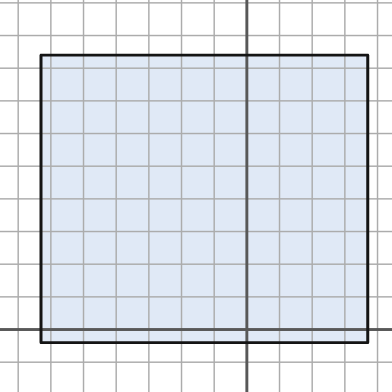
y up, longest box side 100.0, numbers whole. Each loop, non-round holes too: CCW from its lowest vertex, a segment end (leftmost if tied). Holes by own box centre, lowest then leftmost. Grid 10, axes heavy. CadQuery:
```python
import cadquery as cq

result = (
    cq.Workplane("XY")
    .moveTo(-63.0, -4.0)
    .lineTo(37.0, -4.0)
    .lineTo(37.0, 84.0)
    .lineTo(-63.0, 84.0)
    .close()
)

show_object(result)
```